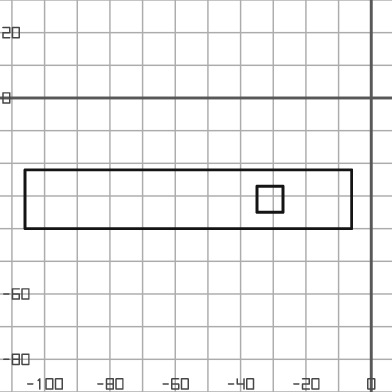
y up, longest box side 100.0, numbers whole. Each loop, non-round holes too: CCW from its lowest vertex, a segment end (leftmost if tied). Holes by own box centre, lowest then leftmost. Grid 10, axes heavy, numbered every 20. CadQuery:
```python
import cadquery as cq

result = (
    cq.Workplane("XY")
    .moveTo(-106.0, -40.0)
    .lineTo(-6.0, -40.0)
    .lineTo(-6.0, -22.0)
    .lineTo(-106.0, -22.0)
    .close()
    .moveTo(-35.0, -35.0)
    .lineTo(-27.0, -35.0)
    .lineTo(-27.0, -27.0)
    .lineTo(-35.0, -27.0)
    .close()
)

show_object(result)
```